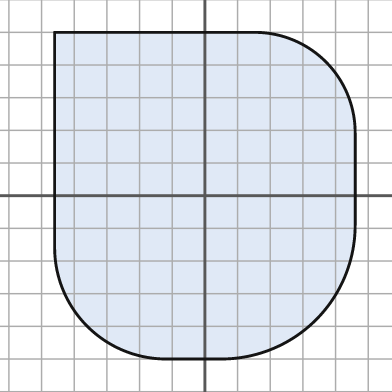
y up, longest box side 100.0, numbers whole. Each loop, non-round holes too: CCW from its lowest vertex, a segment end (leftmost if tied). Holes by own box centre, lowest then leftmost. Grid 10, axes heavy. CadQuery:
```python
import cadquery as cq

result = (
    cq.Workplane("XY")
    .moveTo(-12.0, -50.0)
    .lineTo(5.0, -50.0)
    .threePointArc((34.0, -38.0), (46.0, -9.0))
    .lineTo(46.0, 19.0)
    .threePointArc((37.0, 41.0), (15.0, 50.0))
    .lineTo(-46.0, 50.0)
    .lineTo(-46.0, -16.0)
    .threePointArc((-36.0, -40.0), (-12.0, -50.0))
    .close()
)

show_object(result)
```